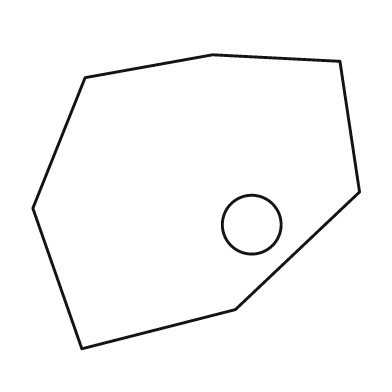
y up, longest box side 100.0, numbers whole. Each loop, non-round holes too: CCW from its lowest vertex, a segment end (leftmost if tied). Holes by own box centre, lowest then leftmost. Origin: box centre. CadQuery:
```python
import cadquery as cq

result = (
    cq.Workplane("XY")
    .moveTo(-35.0, -45.0)
    .lineTo(12.0, -33.0)
    .lineTo(50.0, 3.0)
    .lineTo(44.0, 43.0)
    .lineTo(5.0, 45.0)
    .lineTo(-34.0, 38.0)
    .lineTo(-50.0, -2.0)
    .close()
    .moveTo(17.0, -7.0)
    .circle(9.0)
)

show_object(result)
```